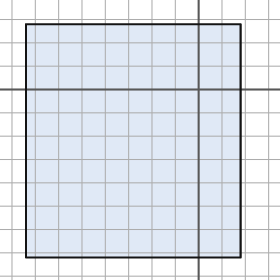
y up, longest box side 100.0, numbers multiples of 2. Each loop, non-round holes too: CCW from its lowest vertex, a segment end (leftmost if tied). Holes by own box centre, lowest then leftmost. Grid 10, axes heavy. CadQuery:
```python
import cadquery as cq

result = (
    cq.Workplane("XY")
    .moveTo(-74.0, -72.0)
    .lineTo(18.0, -72.0)
    .lineTo(18.0, 28.0)
    .lineTo(-74.0, 28.0)
    .close()
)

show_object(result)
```